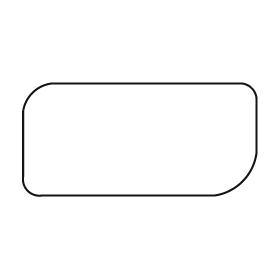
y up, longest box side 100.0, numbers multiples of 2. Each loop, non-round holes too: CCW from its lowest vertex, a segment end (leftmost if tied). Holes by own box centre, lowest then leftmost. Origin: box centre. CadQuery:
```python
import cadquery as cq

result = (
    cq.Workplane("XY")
    .moveTo(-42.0, -24.0)
    .lineTo(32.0, -24.0)
    .threePointArc((44.0, -18.0), (50.0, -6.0))
    .lineTo(50.0, 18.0)
    .threePointArc((48.0, 22.0), (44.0, 24.0))
    .lineTo(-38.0, 24.0)
    .threePointArc((-46.0, 20.0), (-50.0, 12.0))
    .lineTo(-50.0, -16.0)
    .threePointArc((-48.0, -22.0), (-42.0, -24.0))
    .close()
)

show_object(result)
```